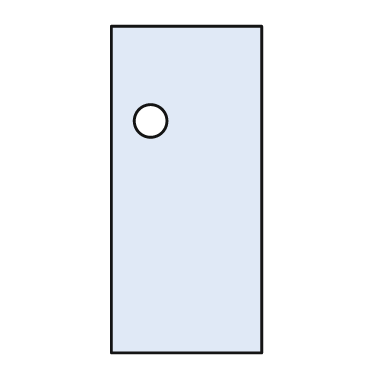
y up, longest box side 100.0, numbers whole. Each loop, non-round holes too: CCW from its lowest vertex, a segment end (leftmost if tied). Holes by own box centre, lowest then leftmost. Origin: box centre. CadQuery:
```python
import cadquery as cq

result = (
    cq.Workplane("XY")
    .moveTo(-23.0, -50.0)
    .lineTo(23.0, -50.0)
    .lineTo(23.0, 50.0)
    .lineTo(-23.0, 50.0)
    .close()
    .moveTo(-11.0, 21.0)
    .circle(5.0)
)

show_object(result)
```